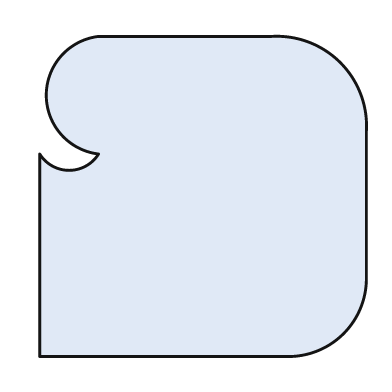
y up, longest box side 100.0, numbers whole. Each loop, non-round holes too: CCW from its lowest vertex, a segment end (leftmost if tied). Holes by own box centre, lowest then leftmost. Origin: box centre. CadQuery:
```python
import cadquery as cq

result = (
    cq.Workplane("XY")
    .moveTo(-50.0, -49.0)
    .lineTo(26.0, -49.0)
    .threePointArc((43.0, -42.0), (50.0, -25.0))
    .lineTo(50.0, 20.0)
    .threePointArc((42.0, 41.0), (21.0, 49.0))
    .lineTo(-32.0, 49.0)
    .threePointArc((-48.0, 31.0), (-32.0, 13.0))
    .threePointArc((-41.0, 8.0), (-50.0, 13.0))
    .close()
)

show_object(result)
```